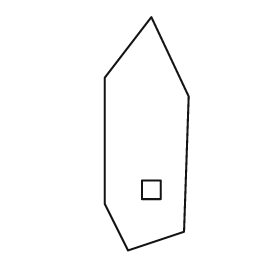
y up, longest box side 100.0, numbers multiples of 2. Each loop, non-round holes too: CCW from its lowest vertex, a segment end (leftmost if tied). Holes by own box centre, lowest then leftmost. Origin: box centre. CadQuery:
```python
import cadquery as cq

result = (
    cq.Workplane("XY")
    .moveTo(-8.0, -50.0)
    .lineTo(16.0, -42.0)
    .lineTo(18.0, 16.0)
    .lineTo(2.0, 50.0)
    .lineTo(-18.0, 24.0)
    .lineTo(-18.0, -30.0)
    .close()
    .moveTo(-2.0, -28.0)
    .lineTo(6.0, -28.0)
    .lineTo(6.0, -20.0)
    .lineTo(-2.0, -20.0)
    .close()
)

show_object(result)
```